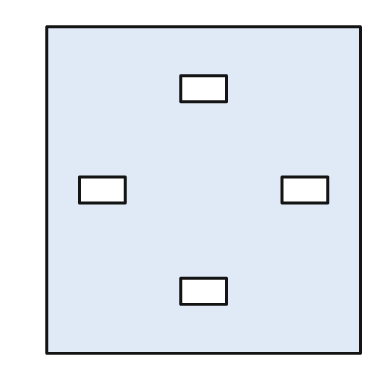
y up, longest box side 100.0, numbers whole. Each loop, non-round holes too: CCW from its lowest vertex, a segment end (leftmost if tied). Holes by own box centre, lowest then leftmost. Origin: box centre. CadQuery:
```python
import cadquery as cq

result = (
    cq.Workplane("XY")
    .moveTo(-48.0, -50.0)
    .lineTo(48.0, -50.0)
    .lineTo(48.0, 50.0)
    .lineTo(-48.0, 50.0)
    .close()
    .moveTo(-7.0, -35.0)
    .lineTo(7.0, -35.0)
    .lineTo(7.0, -27.0)
    .lineTo(-7.0, -27.0)
    .close()
    .moveTo(-38.0, -4.0)
    .lineTo(-24.0, -4.0)
    .lineTo(-24.0, 4.0)
    .lineTo(-38.0, 4.0)
    .close()
    .moveTo(24.0, -4.0)
    .lineTo(38.0, -4.0)
    .lineTo(38.0, 4.0)
    .lineTo(24.0, 4.0)
    .close()
    .moveTo(-7.0, 27.0)
    .lineTo(7.0, 27.0)
    .lineTo(7.0, 35.0)
    .lineTo(-7.0, 35.0)
    .close()
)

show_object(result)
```